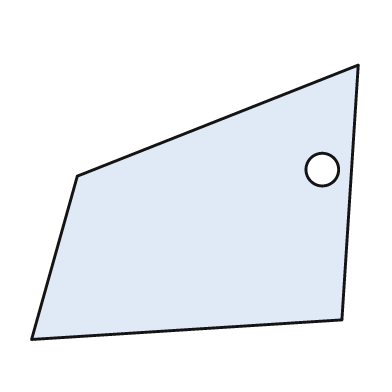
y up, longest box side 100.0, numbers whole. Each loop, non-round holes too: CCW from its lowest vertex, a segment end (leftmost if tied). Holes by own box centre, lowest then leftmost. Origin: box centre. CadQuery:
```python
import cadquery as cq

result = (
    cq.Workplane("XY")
    .moveTo(-50.0, -42.0)
    .lineTo(45.0, -36.0)
    .lineTo(50.0, 42.0)
    .lineTo(-36.0, 8.0)
    .close()
    .moveTo(39.0, 10.0)
    .circle(5.0)
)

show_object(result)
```